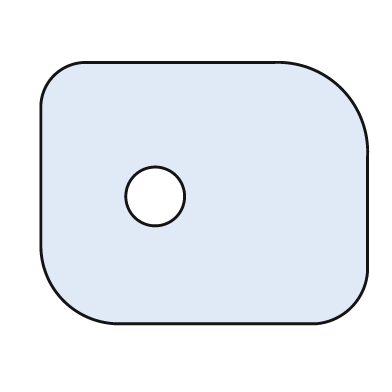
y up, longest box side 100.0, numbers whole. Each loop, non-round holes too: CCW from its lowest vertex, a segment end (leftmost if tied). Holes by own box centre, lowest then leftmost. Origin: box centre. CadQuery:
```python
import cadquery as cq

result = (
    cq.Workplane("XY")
    .moveTo(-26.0, -40.0)
    .lineTo(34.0, -40.0)
    .threePointArc((45.0, -35.0), (50.0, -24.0))
    .lineTo(50.0, 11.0)
    .threePointArc((42.0, 32.0), (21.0, 40.0))
    .lineTo(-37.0, 40.0)
    .threePointArc((-46.0, 36.0), (-50.0, 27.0))
    .lineTo(-50.0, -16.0)
    .threePointArc((-43.0, -33.0), (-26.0, -40.0))
    .close()
    .moveTo(-15.0, -1.0)
    .circle(9.0)
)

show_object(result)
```